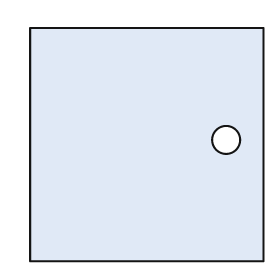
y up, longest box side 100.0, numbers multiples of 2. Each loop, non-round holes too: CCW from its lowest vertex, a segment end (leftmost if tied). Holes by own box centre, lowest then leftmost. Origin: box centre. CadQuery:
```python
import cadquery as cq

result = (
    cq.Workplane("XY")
    .moveTo(-50.0, -50.0)
    .lineTo(50.0, -50.0)
    .lineTo(50.0, 50.0)
    .lineTo(-50.0, 50.0)
    .close()
    .moveTo(34.0, 2.0)
    .circle(6.0)
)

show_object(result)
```